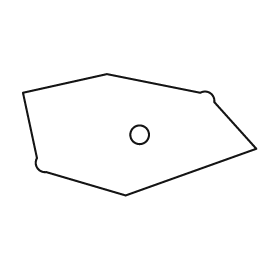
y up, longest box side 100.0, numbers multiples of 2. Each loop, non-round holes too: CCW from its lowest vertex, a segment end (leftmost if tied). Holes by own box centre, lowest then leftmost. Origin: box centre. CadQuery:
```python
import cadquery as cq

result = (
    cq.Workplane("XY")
    .moveTo(-6.0, -26.0)
    .lineTo(50.0, -6.0)
    .lineTo(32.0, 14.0)
    .threePointArc((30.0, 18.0), (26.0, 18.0))
    .lineTo(-14.0, 26.0)
    .lineTo(-50.0, 18.0)
    .lineTo(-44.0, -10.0)
    .threePointArc((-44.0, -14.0), (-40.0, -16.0))
    .close()
    .moveTo(0.0, 0.0)
    .circle(4.0)
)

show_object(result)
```